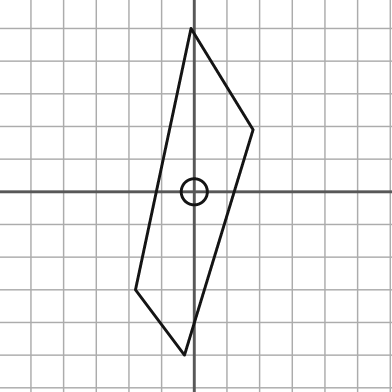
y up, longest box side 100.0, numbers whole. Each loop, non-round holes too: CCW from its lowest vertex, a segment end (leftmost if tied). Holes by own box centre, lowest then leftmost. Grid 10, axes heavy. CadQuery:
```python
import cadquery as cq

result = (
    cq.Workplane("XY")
    .moveTo(-3.0, -50.0)
    .lineTo(18.0, 19.0)
    .lineTo(-1.0, 50.0)
    .lineTo(-18.0, -30.0)
    .close()
    .moveTo(0.0, 0.0)
    .circle(4.0)
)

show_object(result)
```